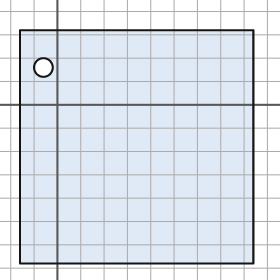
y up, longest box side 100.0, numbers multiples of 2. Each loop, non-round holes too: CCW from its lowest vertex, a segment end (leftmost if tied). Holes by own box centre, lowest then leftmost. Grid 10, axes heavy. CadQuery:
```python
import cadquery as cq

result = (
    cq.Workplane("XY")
    .moveTo(-16.0, -68.0)
    .lineTo(84.0, -68.0)
    .lineTo(84.0, 32.0)
    .lineTo(-16.0, 32.0)
    .close()
    .moveTo(-6.0, 16.0)
    .circle(4.0)
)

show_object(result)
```